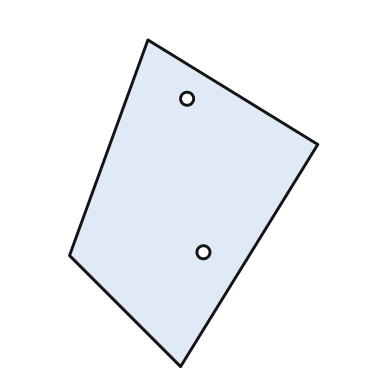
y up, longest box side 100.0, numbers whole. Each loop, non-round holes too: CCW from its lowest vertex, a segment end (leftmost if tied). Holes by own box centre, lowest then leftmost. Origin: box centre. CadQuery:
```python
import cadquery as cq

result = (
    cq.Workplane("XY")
    .moveTo(-4.0, -50.0)
    .lineTo(38.0, 18.0)
    .lineTo(-14.0, 50.0)
    .lineTo(-38.0, -16.0)
    .close()
    .moveTo(3.0, -15.0)
    .circle(2.0)
    .moveTo(-2.0, 32.0)
    .circle(2.0)
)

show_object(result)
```